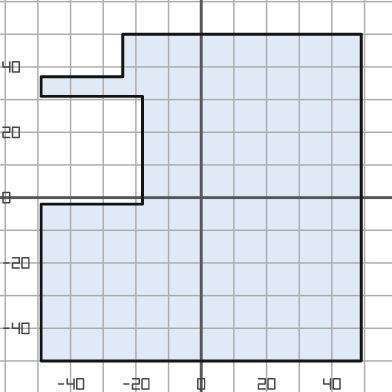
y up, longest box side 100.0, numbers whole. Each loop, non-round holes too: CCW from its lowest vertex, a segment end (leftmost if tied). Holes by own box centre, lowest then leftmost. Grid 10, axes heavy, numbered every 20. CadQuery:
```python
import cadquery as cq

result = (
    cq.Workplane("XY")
    .moveTo(-49.0, -50.0)
    .lineTo(49.0, -50.0)
    .lineTo(49.0, 50.0)
    .lineTo(-24.0, 50.0)
    .lineTo(-24.0, 37.0)
    .lineTo(-49.0, 37.0)
    .lineTo(-49.0, 31.0)
    .lineTo(-18.0, 31.0)
    .lineTo(-18.0, -2.0)
    .lineTo(-49.0, -2.0)
    .close()
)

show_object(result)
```